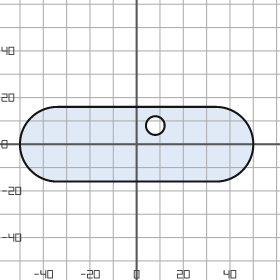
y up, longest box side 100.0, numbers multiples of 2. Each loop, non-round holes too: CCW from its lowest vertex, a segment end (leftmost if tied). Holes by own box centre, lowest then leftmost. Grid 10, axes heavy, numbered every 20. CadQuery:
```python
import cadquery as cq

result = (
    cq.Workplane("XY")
    .moveTo(-34.0, -16.0)
    .lineTo(34.0, -16.0)
    .threePointArc((50.0, 0.0), (34.0, 16.0))
    .lineTo(-34.0, 16.0)
    .threePointArc((-50.0, 0.0), (-34.0, -16.0))
    .close()
    .moveTo(8.0, 8.0)
    .circle(4.0)
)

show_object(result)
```